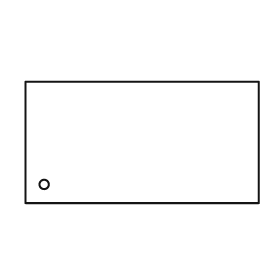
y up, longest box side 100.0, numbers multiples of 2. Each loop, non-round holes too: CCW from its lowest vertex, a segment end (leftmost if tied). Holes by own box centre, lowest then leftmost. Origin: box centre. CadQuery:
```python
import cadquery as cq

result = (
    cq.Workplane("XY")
    .moveTo(-50.0, -26.0)
    .lineTo(50.0, -26.0)
    .lineTo(50.0, 26.0)
    .lineTo(-50.0, 26.0)
    .close()
    .moveTo(-42.0, -18.0)
    .circle(2.0)
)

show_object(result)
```